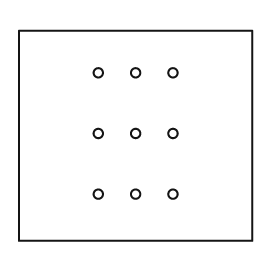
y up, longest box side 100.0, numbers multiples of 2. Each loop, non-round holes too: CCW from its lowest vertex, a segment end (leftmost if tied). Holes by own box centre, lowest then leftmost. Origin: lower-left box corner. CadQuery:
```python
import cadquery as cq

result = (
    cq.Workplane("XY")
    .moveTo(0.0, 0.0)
    .lineTo(100.0, 0.0)
    .lineTo(100.0, 90.0)
    .lineTo(0.0, 90.0)
    .close()
    .moveTo(34.0, 20.0)
    .circle(2.0)
    .moveTo(50.0, 20.0)
    .circle(2.0)
    .moveTo(66.0, 20.0)
    .circle(2.0)
    .moveTo(34.0, 46.0)
    .circle(2.0)
    .moveTo(50.0, 46.0)
    .circle(2.0)
    .moveTo(66.0, 46.0)
    .circle(2.0)
    .moveTo(34.0, 72.0)
    .circle(2.0)
    .moveTo(50.0, 72.0)
    .circle(2.0)
    .moveTo(66.0, 72.0)
    .circle(2.0)
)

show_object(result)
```